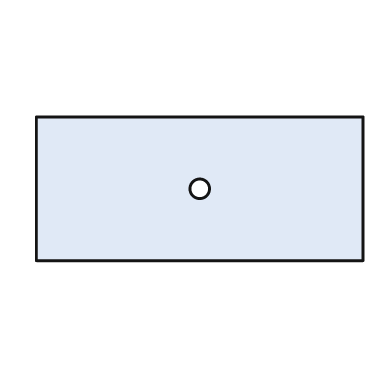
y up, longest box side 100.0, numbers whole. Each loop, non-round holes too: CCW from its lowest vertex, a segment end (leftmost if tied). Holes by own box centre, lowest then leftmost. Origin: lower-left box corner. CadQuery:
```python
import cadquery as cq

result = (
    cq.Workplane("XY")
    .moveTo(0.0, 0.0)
    .lineTo(100.0, 0.0)
    .lineTo(100.0, 44.0)
    .lineTo(0.0, 44.0)
    .close()
    .moveTo(50.0, 22.0)
    .circle(3.0)
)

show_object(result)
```